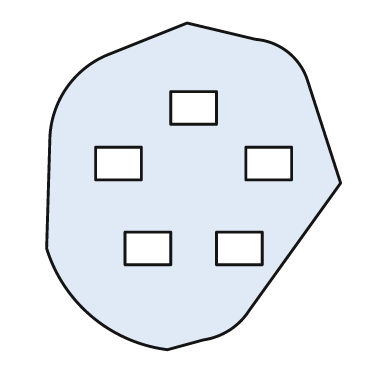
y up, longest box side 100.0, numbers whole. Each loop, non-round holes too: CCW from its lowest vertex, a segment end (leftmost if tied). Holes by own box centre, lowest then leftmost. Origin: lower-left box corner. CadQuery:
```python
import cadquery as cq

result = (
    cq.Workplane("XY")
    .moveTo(37.0, 0.0)
    .lineTo(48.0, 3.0)
    .threePointArc((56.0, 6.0), (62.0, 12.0))
    .lineTo(90.0, 51.0)
    .lineTo(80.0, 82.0)
    .threePointArc((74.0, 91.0), (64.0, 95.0))
    .lineTo(43.0, 100.0)
    .lineTo(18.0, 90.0)
    .threePointArc((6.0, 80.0), (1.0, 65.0))
    .lineTo(0.0, 31.0)
    .threePointArc((14.0, 10.0), (37.0, 0.0))
    .close()
    .moveTo(24.0, 26.0)
    .lineTo(38.0, 26.0)
    .lineTo(38.0, 36.0)
    .lineTo(24.0, 36.0)
    .close()
    .moveTo(52.0, 26.0)
    .lineTo(66.0, 26.0)
    .lineTo(66.0, 36.0)
    .lineTo(52.0, 36.0)
    .close()
    .moveTo(15.0, 52.0)
    .lineTo(29.0, 52.0)
    .lineTo(29.0, 62.0)
    .lineTo(15.0, 62.0)
    .close()
    .moveTo(61.0, 52.0)
    .lineTo(75.0, 52.0)
    .lineTo(75.0, 62.0)
    .lineTo(61.0, 62.0)
    .close()
    .moveTo(38.0, 69.0)
    .lineTo(52.0, 69.0)
    .lineTo(52.0, 79.0)
    .lineTo(38.0, 79.0)
    .close()
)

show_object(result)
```